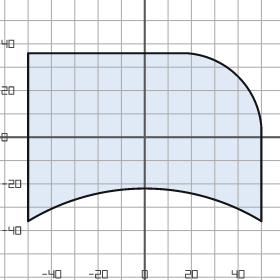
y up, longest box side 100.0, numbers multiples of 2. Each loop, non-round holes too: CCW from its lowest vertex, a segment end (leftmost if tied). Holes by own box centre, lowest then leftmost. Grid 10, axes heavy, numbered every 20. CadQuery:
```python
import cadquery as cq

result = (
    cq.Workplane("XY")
    .moveTo(-50.0, -36.0)
    .threePointArc((0.0, -22.0), (50.0, -36.0))
    .lineTo(50.0, 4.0)
    .threePointArc((40.0, 26.0), (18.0, 36.0))
    .lineTo(-50.0, 36.0)
    .close()
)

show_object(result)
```